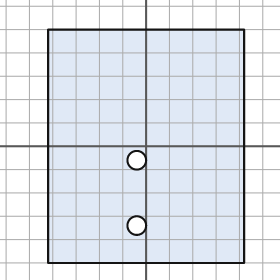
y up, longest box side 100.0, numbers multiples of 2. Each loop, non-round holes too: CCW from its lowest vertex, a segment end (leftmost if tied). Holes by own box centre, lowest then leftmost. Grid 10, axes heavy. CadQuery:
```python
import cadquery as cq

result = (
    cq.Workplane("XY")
    .moveTo(-42.0, -50.0)
    .lineTo(42.0, -50.0)
    .lineTo(42.0, 50.0)
    .lineTo(-42.0, 50.0)
    .close()
    .moveTo(-4.0, -34.0)
    .circle(4.0)
    .moveTo(-4.0, -6.0)
    .circle(4.0)
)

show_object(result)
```